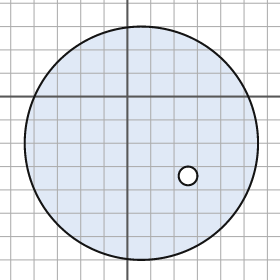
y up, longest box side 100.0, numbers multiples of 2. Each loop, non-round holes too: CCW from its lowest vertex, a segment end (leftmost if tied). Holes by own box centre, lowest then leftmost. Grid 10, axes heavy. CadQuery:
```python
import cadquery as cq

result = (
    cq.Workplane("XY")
    .moveTo(6.0, -20.0)
    .circle(50.0)
    .moveTo(26.0, -34.0)
    .circle(4.0)
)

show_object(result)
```